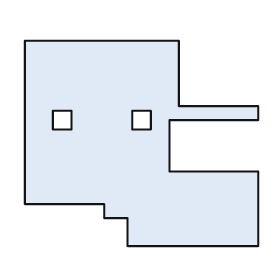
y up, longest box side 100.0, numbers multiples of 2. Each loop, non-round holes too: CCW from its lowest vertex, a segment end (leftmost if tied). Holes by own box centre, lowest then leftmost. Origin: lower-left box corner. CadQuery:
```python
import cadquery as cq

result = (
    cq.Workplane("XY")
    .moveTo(44.0, 0.0)
    .lineTo(100.0, 0.0)
    .lineTo(100.0, 32.0)
    .lineTo(62.0, 32.0)
    .lineTo(62.0, 54.0)
    .lineTo(100.0, 54.0)
    .lineTo(100.0, 60.0)
    .lineTo(66.0, 60.0)
    .lineTo(66.0, 88.0)
    .lineTo(0.0, 88.0)
    .lineTo(0.0, 18.0)
    .lineTo(34.0, 18.0)
    .lineTo(34.0, 12.0)
    .lineTo(44.0, 12.0)
    .close()
    .moveTo(12.0, 50.0)
    .lineTo(20.0, 50.0)
    .lineTo(20.0, 58.0)
    .lineTo(12.0, 58.0)
    .close()
    .moveTo(46.0, 50.0)
    .lineTo(54.0, 50.0)
    .lineTo(54.0, 58.0)
    .lineTo(46.0, 58.0)
    .close()
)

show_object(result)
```